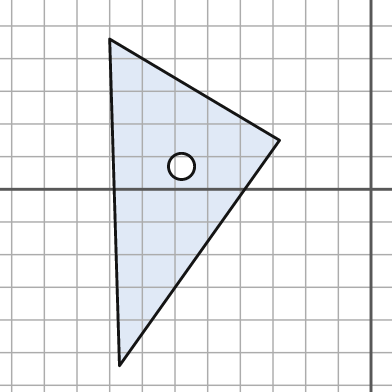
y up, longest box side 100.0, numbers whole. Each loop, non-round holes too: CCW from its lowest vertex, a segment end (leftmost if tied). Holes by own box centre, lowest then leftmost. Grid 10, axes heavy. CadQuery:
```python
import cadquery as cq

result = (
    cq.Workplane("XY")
    .moveTo(-77.0, -54.0)
    .lineTo(-28.0, 15.0)
    .lineTo(-80.0, 46.0)
    .close()
    .moveTo(-58.0, 7.0)
    .circle(4.0)
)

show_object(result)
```